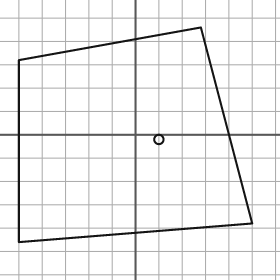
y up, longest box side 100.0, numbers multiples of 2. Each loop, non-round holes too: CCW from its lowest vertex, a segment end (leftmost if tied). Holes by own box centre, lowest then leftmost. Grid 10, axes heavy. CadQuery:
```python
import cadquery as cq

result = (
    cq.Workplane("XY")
    .moveTo(-50.0, -46.0)
    .lineTo(50.0, -38.0)
    .lineTo(28.0, 46.0)
    .lineTo(-50.0, 32.0)
    .close()
    .moveTo(10.0, -2.0)
    .circle(2.0)
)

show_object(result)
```